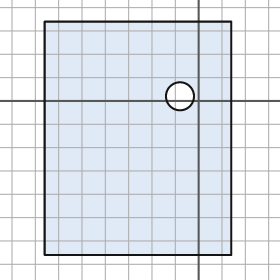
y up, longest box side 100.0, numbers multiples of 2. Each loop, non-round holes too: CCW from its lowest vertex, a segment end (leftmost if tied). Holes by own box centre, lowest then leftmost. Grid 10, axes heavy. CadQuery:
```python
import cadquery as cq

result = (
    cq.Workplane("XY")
    .moveTo(-66.0, -66.0)
    .lineTo(14.0, -66.0)
    .lineTo(14.0, 34.0)
    .lineTo(-66.0, 34.0)
    .close()
    .moveTo(-8.0, 2.0)
    .circle(6.0)
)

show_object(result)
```